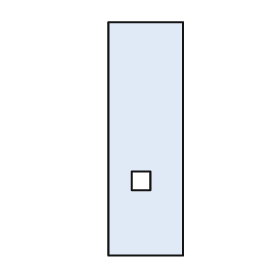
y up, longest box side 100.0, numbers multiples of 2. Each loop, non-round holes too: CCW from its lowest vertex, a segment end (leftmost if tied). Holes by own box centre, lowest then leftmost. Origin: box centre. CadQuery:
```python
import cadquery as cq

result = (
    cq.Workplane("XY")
    .moveTo(-16.0, -50.0)
    .lineTo(16.0, -50.0)
    .lineTo(16.0, 50.0)
    .lineTo(-16.0, 50.0)
    .close()
    .moveTo(-6.0, -22.0)
    .lineTo(2.0, -22.0)
    .lineTo(2.0, -14.0)
    .lineTo(-6.0, -14.0)
    .close()
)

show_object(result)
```